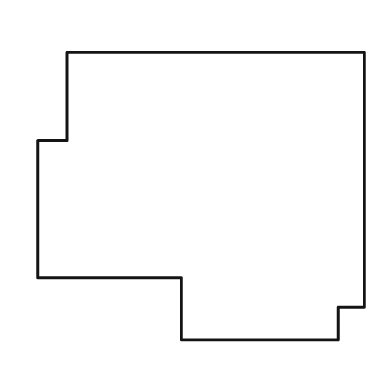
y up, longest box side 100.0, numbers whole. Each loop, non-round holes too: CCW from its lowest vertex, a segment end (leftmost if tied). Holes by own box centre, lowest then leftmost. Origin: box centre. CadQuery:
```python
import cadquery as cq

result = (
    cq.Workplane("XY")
    .moveTo(-6.0, -44.0)
    .lineTo(42.0, -44.0)
    .lineTo(42.0, -34.0)
    .lineTo(50.0, -34.0)
    .lineTo(50.0, 44.0)
    .lineTo(-41.0, 44.0)
    .lineTo(-41.0, 17.0)
    .lineTo(-50.0, 17.0)
    .lineTo(-50.0, -25.0)
    .lineTo(-6.0, -25.0)
    .close()
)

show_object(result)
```